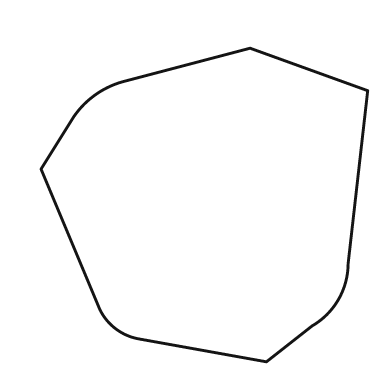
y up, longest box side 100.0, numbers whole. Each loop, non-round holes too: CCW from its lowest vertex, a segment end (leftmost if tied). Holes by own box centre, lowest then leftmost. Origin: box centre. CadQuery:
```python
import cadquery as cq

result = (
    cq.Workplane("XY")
    .moveTo(19.0, -48.0)
    .lineTo(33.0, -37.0)
    .threePointArc((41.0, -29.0), (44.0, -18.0))
    .lineTo(50.0, 35.0)
    .lineTo(14.0, 48.0)
    .lineTo(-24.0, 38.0)
    .threePointArc((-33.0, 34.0), (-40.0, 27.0))
    .lineTo(-50.0, 11.0)
    .lineTo(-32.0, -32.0)
    .threePointArc((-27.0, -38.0), (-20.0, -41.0))
    .close()
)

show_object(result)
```